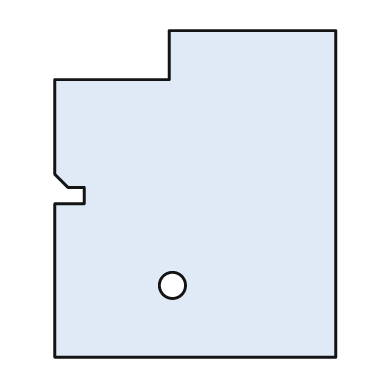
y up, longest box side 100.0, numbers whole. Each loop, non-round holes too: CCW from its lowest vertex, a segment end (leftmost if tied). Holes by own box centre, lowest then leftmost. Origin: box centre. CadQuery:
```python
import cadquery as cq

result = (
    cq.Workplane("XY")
    .moveTo(-43.0, -50.0)
    .lineTo(43.0, -50.0)
    .lineTo(43.0, 50.0)
    .lineTo(-8.0, 50.0)
    .lineTo(-8.0, 35.0)
    .lineTo(-43.0, 35.0)
    .lineTo(-43.0, 6.0)
    .lineTo(-39.0, 2.0)
    .lineTo(-34.0, 2.0)
    .lineTo(-34.0, -3.0)
    .lineTo(-43.0, -3.0)
    .close()
    .moveTo(-7.0, -28.0)
    .circle(4.0)
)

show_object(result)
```